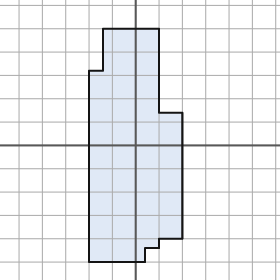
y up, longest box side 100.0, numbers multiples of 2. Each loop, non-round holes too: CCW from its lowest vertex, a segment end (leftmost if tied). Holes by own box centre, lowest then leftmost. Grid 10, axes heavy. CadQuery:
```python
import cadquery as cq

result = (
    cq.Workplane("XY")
    .moveTo(-20.0, -50.0)
    .lineTo(4.0, -50.0)
    .lineTo(4.0, -44.0)
    .lineTo(10.0, -44.0)
    .lineTo(10.0, -40.0)
    .lineTo(20.0, -40.0)
    .lineTo(20.0, 14.0)
    .lineTo(10.0, 14.0)
    .lineTo(10.0, 50.0)
    .lineTo(-14.0, 50.0)
    .lineTo(-14.0, 32.0)
    .lineTo(-20.0, 32.0)
    .close()
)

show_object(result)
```